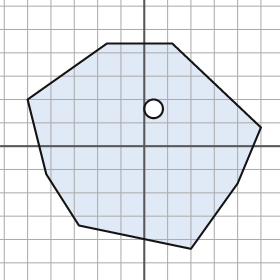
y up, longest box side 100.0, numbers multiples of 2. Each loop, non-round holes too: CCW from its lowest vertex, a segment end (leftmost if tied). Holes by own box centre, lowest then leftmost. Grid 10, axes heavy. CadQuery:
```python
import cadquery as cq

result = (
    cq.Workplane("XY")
    .moveTo(20.0, -44.0)
    .lineTo(40.0, -16.0)
    .lineTo(50.0, 8.0)
    .lineTo(12.0, 44.0)
    .lineTo(-16.0, 44.0)
    .lineTo(-50.0, 20.0)
    .lineTo(-42.0, -12.0)
    .lineTo(-28.0, -34.0)
    .close()
    .moveTo(4.0, 16.0)
    .circle(4.0)
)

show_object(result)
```